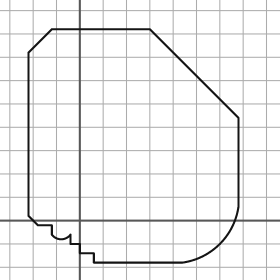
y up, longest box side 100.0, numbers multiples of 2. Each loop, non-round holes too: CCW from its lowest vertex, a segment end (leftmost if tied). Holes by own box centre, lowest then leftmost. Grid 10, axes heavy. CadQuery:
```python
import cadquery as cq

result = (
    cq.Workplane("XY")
    .moveTo(6.0, -18.0)
    .lineTo(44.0, -18.0)
    .threePointArc((60.0, -10.0), (68.0, 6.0))
    .lineTo(68.0, 44.0)
    .lineTo(30.0, 82.0)
    .lineTo(-12.0, 82.0)
    .lineTo(-22.0, 72.0)
    .lineTo(-22.0, 2.0)
    .lineTo(-18.0, -2.0)
    .lineTo(-12.0, -2.0)
    .lineTo(-12.0, -6.0)
    .threePointArc((-8.0, -8.0), (-4.0, -6.0))
    .lineTo(-4.0, -10.0)
    .lineTo(0.0, -10.0)
    .lineTo(0.0, -14.0)
    .lineTo(6.0, -14.0)
    .close()
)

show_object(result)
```